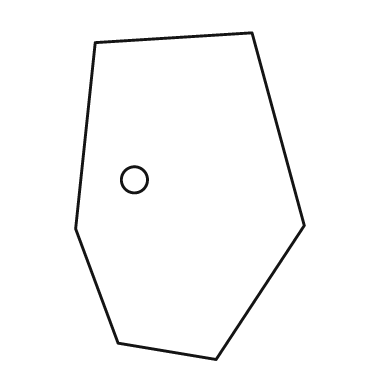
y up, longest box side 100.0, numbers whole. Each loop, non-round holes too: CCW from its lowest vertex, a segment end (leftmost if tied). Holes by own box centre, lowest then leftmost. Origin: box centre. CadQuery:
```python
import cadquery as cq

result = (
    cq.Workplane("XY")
    .moveTo(8.0, -50.0)
    .lineTo(35.0, -9.0)
    .lineTo(19.0, 50.0)
    .lineTo(-29.0, 47.0)
    .lineTo(-35.0, -10.0)
    .lineTo(-22.0, -45.0)
    .close()
    .moveTo(-17.0, 5.0)
    .circle(4.0)
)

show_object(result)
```